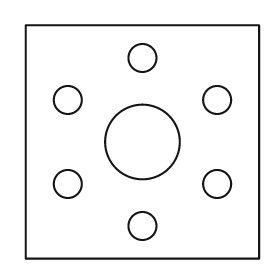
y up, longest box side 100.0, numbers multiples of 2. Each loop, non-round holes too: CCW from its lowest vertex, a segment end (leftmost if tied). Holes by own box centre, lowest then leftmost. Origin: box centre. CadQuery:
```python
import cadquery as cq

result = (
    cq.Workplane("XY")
    .moveTo(-50.0, -50.0)
    .lineTo(50.0, -50.0)
    .lineTo(50.0, 50.0)
    .lineTo(-50.0, 50.0)
    .close()
    .moveTo(0.0, -36.0)
    .circle(6.0)
    .moveTo(-32.0, -18.0)
    .circle(6.0)
    .moveTo(32.0, -18.0)
    .circle(6.0)
    .moveTo(0.0, 0.0)
    .circle(16.0)
    .moveTo(-32.0, 18.0)
    .circle(6.0)
    .moveTo(32.0, 18.0)
    .circle(6.0)
    .moveTo(0.0, 36.0)
    .circle(6.0)
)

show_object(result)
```